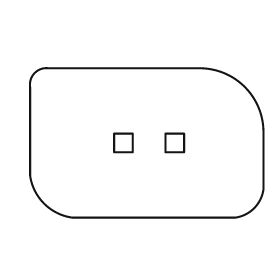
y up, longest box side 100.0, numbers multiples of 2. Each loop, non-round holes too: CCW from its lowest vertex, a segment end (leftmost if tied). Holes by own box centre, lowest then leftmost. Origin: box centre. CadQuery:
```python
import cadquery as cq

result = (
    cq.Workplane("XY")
    .moveTo(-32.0, -32.0)
    .lineTo(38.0, -32.0)
    .threePointArc((46.0, -28.0), (50.0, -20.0))
    .lineTo(50.0, 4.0)
    .threePointArc((42.0, 24.0), (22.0, 32.0))
    .lineTo(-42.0, 32.0)
    .threePointArc((-48.0, 30.0), (-50.0, 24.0))
    .lineTo(-50.0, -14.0)
    .threePointArc((-44.0, -26.0), (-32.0, -32.0))
    .close()
    .moveTo(-14.0, -4.0)
    .lineTo(-6.0, -4.0)
    .lineTo(-6.0, 4.0)
    .lineTo(-14.0, 4.0)
    .close()
    .moveTo(8.0, -4.0)
    .lineTo(16.0, -4.0)
    .lineTo(16.0, 4.0)
    .lineTo(8.0, 4.0)
    .close()
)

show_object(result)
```